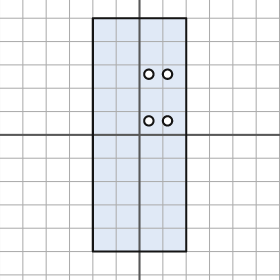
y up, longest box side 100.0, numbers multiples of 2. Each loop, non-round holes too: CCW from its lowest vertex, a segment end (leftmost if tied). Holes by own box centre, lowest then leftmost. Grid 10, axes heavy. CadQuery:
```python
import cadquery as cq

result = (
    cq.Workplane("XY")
    .moveTo(-20.0, -50.0)
    .lineTo(20.0, -50.0)
    .lineTo(20.0, 50.0)
    .lineTo(-20.0, 50.0)
    .close()
    .moveTo(4.0, 6.0)
    .circle(2.0)
    .moveTo(12.0, 6.0)
    .circle(2.0)
    .moveTo(4.0, 26.0)
    .circle(2.0)
    .moveTo(12.0, 26.0)
    .circle(2.0)
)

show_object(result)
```